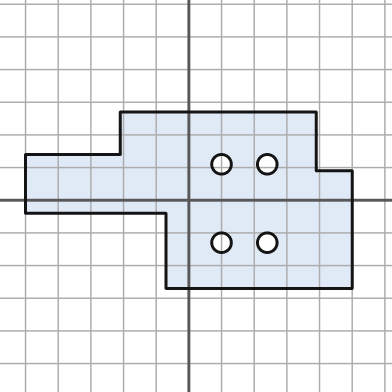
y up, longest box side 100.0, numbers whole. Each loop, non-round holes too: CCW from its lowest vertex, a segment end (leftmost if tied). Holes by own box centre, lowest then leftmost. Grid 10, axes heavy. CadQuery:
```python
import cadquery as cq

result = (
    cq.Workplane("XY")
    .moveTo(-7.0, -27.0)
    .lineTo(50.0, -27.0)
    .lineTo(50.0, 9.0)
    .lineTo(39.0, 9.0)
    .lineTo(39.0, 27.0)
    .lineTo(-21.0, 27.0)
    .lineTo(-21.0, 14.0)
    .lineTo(-50.0, 14.0)
    .lineTo(-50.0, -4.0)
    .lineTo(-7.0, -4.0)
    .close()
    .moveTo(10.0, -13.0)
    .circle(3.0)
    .moveTo(24.0, -13.0)
    .circle(3.0)
    .moveTo(10.0, 11.0)
    .circle(3.0)
    .moveTo(24.0, 11.0)
    .circle(3.0)
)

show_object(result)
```